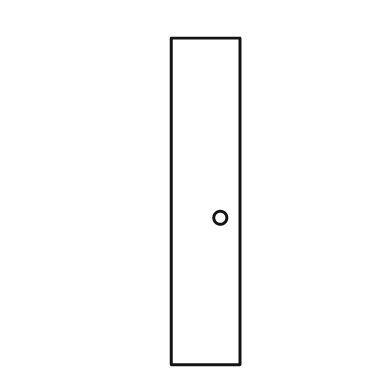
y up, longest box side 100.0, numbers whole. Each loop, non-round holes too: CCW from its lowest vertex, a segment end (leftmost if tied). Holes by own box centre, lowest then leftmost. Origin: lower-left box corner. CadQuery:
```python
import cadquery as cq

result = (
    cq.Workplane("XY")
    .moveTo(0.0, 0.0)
    .lineTo(21.0, 0.0)
    .lineTo(21.0, 100.0)
    .lineTo(0.0, 100.0)
    .close()
    .moveTo(15.0, 45.0)
    .circle(2.0)
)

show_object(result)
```